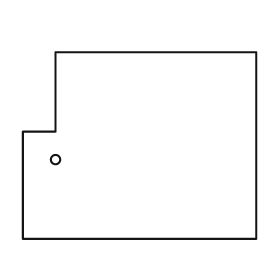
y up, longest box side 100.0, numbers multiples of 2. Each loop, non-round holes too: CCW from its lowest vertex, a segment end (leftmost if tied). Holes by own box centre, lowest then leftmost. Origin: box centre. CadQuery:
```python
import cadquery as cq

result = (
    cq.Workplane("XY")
    .moveTo(-50.0, -40.0)
    .lineTo(50.0, -40.0)
    .lineTo(50.0, 40.0)
    .lineTo(-36.0, 40.0)
    .lineTo(-36.0, 6.0)
    .lineTo(-50.0, 6.0)
    .close()
    .moveTo(-36.0, -6.0)
    .circle(2.0)
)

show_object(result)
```